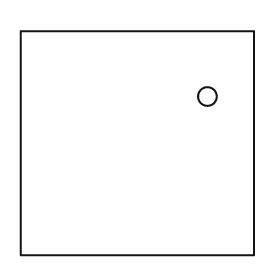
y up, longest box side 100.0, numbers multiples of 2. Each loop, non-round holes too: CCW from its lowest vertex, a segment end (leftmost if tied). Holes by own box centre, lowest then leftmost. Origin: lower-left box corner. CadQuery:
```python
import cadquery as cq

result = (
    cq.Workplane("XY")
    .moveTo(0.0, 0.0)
    .lineTo(100.0, 0.0)
    .lineTo(100.0, 96.0)
    .lineTo(0.0, 96.0)
    .close()
    .moveTo(80.0, 68.0)
    .circle(4.0)
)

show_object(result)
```